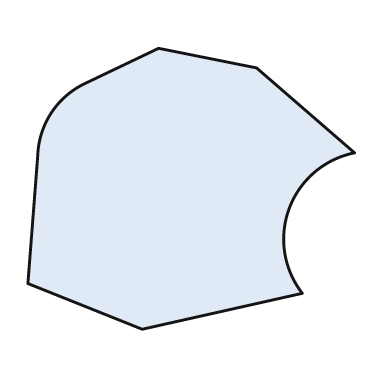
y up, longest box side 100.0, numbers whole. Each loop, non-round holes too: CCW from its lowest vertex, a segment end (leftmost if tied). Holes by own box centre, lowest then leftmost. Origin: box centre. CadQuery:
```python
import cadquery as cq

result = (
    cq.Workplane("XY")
    .moveTo(-15.0, -43.0)
    .lineTo(34.0, -32.0)
    .threePointArc((30.0, -6.0), (50.0, 11.0))
    .lineTo(20.0, 37.0)
    .lineTo(-10.0, 43.0)
    .lineTo(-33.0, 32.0)
    .threePointArc((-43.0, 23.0), (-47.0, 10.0))
    .lineTo(-50.0, -29.0)
    .close()
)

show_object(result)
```